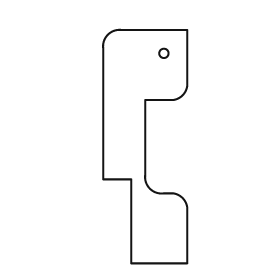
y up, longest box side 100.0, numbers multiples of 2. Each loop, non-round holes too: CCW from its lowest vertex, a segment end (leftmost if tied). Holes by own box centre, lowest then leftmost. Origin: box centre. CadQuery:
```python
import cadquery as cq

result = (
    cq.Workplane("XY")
    .moveTo(-6.0, -50.0)
    .lineTo(18.0, -50.0)
    .lineTo(18.0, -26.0)
    .threePointArc((16.0, -22.0), (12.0, -20.0))
    .lineTo(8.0, -20.0)
    .threePointArc((2.0, -18.0), (0.0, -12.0))
    .lineTo(0.0, 20.0)
    .lineTo(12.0, 20.0)
    .threePointArc((16.0, 22.0), (18.0, 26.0))
    .lineTo(18.0, 50.0)
    .lineTo(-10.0, 50.0)
    .threePointArc((-16.0, 48.0), (-18.0, 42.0))
    .lineTo(-18.0, -14.0)
    .lineTo(-6.0, -14.0)
    .close()
    .moveTo(8.0, 40.0)
    .circle(2.0)
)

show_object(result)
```